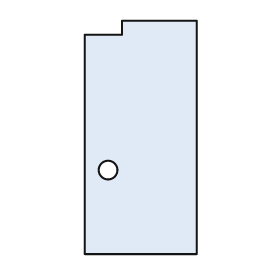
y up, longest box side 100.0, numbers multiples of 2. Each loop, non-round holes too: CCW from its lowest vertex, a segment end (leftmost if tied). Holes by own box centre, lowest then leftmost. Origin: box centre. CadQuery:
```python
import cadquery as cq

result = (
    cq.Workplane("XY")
    .moveTo(-24.0, -50.0)
    .lineTo(24.0, -50.0)
    .lineTo(24.0, 50.0)
    .lineTo(-8.0, 50.0)
    .lineTo(-8.0, 44.0)
    .lineTo(-24.0, 44.0)
    .close()
    .moveTo(-14.0, -14.0)
    .circle(4.0)
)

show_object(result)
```